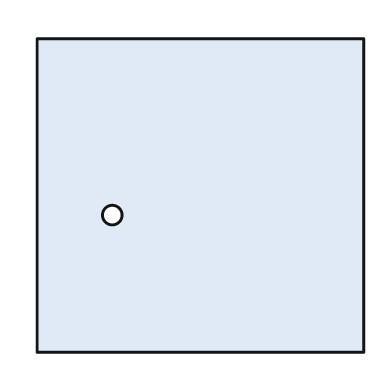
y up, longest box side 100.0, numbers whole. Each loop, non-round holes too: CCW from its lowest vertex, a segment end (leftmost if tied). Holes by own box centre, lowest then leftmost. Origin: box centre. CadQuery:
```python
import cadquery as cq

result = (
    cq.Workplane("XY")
    .moveTo(-50.0, -48.0)
    .lineTo(50.0, -48.0)
    .lineTo(50.0, 48.0)
    .lineTo(-50.0, 48.0)
    .close()
    .moveTo(-27.0, -6.0)
    .circle(3.0)
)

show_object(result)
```